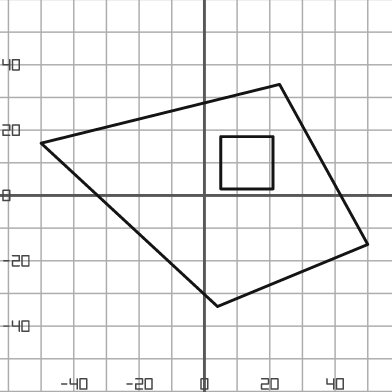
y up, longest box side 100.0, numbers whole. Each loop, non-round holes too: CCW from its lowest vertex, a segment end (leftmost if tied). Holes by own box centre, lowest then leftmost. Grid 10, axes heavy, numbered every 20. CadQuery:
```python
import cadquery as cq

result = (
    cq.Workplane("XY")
    .moveTo(4.0, -34.0)
    .lineTo(50.0, -15.0)
    .lineTo(23.0, 34.0)
    .lineTo(-50.0, 16.0)
    .close()
    .moveTo(5.0, 2.0)
    .lineTo(21.0, 2.0)
    .lineTo(21.0, 18.0)
    .lineTo(5.0, 18.0)
    .close()
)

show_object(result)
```